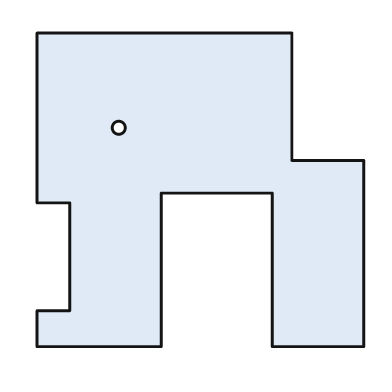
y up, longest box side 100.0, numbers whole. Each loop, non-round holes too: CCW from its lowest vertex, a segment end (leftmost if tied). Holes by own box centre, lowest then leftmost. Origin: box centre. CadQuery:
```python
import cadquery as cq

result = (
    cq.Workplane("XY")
    .moveTo(-50.0, -48.0)
    .lineTo(-12.0, -48.0)
    .lineTo(-12.0, -1.0)
    .lineTo(22.0, -1.0)
    .lineTo(22.0, -48.0)
    .lineTo(50.0, -48.0)
    .lineTo(50.0, 9.0)
    .lineTo(28.0, 9.0)
    .lineTo(28.0, 48.0)
    .lineTo(-50.0, 48.0)
    .lineTo(-50.0, -4.0)
    .lineTo(-40.0, -4.0)
    .lineTo(-40.0, -37.0)
    .lineTo(-50.0, -37.0)
    .close()
    .moveTo(-25.0, 19.0)
    .circle(2.0)
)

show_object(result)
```